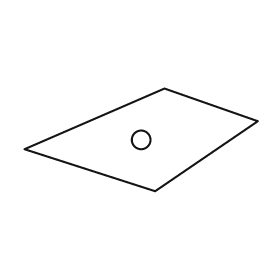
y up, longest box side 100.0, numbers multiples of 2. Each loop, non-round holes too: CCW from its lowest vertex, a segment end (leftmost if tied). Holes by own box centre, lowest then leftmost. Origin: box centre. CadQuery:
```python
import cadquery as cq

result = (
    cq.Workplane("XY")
    .moveTo(6.0, -22.0)
    .lineTo(50.0, 8.0)
    .lineTo(10.0, 22.0)
    .lineTo(-50.0, -4.0)
    .close()
    .moveTo(0.0, 0.0)
    .circle(4.0)
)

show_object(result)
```